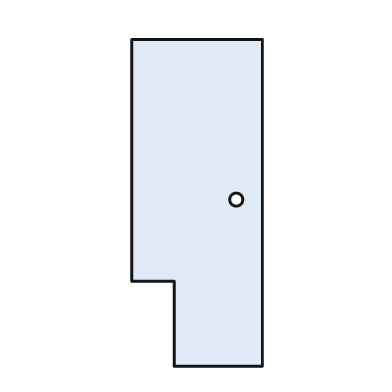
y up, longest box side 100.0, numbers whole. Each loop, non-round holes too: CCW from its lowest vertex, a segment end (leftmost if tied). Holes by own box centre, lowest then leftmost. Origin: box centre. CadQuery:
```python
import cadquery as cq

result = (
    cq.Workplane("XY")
    .moveTo(-7.0, -50.0)
    .lineTo(20.0, -50.0)
    .lineTo(20.0, 50.0)
    .lineTo(-20.0, 50.0)
    .lineTo(-20.0, -24.0)
    .lineTo(-7.0, -24.0)
    .close()
    .moveTo(12.0, 1.0)
    .circle(2.0)
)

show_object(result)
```